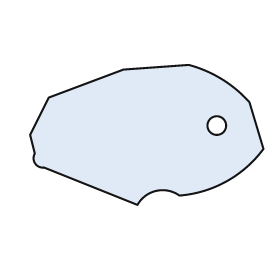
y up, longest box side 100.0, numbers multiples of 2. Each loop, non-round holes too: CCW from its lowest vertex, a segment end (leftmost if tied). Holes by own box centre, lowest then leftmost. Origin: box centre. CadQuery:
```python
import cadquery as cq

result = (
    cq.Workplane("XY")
    .moveTo(-4.0, -30.0)
    .threePointArc((4.0, -24.0), (14.0, -26.0))
    .threePointArc((34.0, -20.0), (50.0, -6.0))
    .lineTo(44.0, 14.0)
    .threePointArc((32.0, 24.0), (18.0, 30.0))
    .lineTo(-10.0, 28.0)
    .lineTo(-42.0, 16.0)
    .lineTo(-50.0, 0.0)
    .lineTo(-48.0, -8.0)
    .threePointArc((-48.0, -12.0), (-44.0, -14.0))
    .close()
    .moveTo(30.0, 4.0)
    .circle(4.0)
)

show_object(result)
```